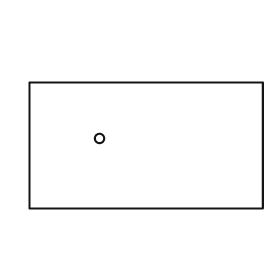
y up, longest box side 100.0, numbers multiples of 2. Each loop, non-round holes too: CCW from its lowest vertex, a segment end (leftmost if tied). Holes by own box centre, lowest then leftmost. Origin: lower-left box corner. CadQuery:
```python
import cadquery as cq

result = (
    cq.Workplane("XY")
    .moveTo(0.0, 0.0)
    .lineTo(100.0, 0.0)
    .lineTo(100.0, 54.0)
    .lineTo(0.0, 54.0)
    .close()
    .moveTo(30.0, 30.0)
    .circle(2.0)
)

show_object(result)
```